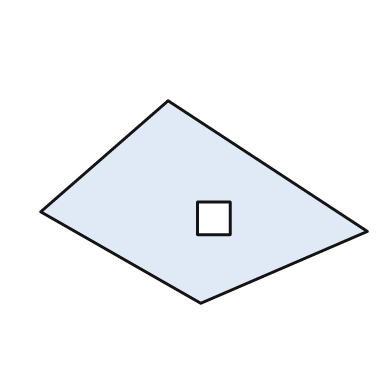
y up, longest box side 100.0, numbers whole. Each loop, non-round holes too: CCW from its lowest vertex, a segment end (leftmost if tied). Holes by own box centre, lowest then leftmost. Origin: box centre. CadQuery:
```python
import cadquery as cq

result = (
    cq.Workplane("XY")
    .moveTo(-1.0, -31.0)
    .lineTo(50.0, -9.0)
    .lineTo(-11.0, 31.0)
    .lineTo(-50.0, -3.0)
    .close()
    .moveTo(-2.0, -10.0)
    .lineTo(8.0, -10.0)
    .lineTo(8.0, 0.0)
    .lineTo(-2.0, 0.0)
    .close()
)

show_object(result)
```